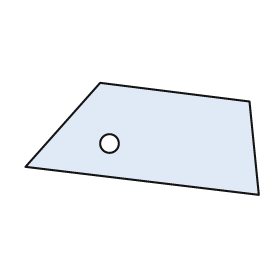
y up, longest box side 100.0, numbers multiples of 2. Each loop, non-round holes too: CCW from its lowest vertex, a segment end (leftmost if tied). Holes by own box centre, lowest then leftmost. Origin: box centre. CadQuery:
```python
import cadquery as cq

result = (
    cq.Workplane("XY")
    .moveTo(50.0, -24.0)
    .lineTo(46.0, 16.0)
    .lineTo(-18.0, 24.0)
    .lineTo(-50.0, -12.0)
    .close()
    .moveTo(-14.0, -2.0)
    .circle(4.0)
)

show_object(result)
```